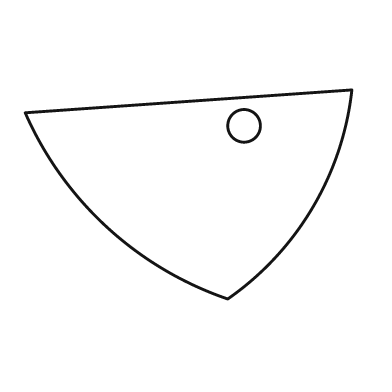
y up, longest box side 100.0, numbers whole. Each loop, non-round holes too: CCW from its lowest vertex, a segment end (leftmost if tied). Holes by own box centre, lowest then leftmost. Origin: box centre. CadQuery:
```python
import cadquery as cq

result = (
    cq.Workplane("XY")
    .moveTo(12.0, -32.0)
    .threePointArc((38.0, -4.0), (50.0, 32.0))
    .lineTo(-50.0, 25.0)
    .threePointArc((-25.0, -10.0), (12.0, -32.0))
    .close()
    .moveTo(17.0, 21.0)
    .circle(5.0)
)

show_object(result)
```